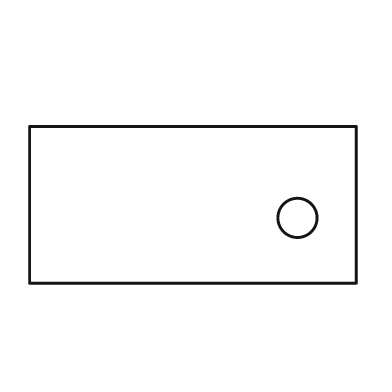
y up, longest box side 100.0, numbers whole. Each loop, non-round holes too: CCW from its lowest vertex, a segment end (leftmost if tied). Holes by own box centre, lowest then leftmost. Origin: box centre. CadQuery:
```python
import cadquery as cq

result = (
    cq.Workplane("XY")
    .moveTo(-50.0, -24.0)
    .lineTo(50.0, -24.0)
    .lineTo(50.0, 24.0)
    .lineTo(-50.0, 24.0)
    .close()
    .moveTo(32.0, -4.0)
    .circle(6.0)
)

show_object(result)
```